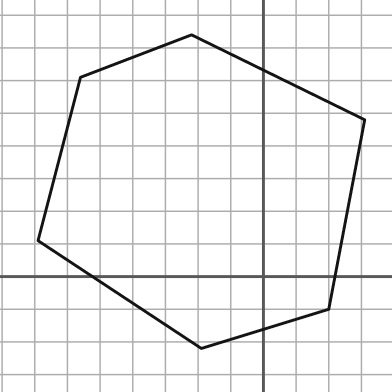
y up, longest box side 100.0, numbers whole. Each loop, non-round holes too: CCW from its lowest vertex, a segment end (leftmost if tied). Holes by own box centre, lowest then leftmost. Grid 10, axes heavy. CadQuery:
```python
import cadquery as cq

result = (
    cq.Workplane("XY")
    .moveTo(-19.0, -22.0)
    .lineTo(20.0, -10.0)
    .lineTo(31.0, 48.0)
    .lineTo(-22.0, 74.0)
    .lineTo(-56.0, 61.0)
    .lineTo(-69.0, 11.0)
    .close()
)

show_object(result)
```